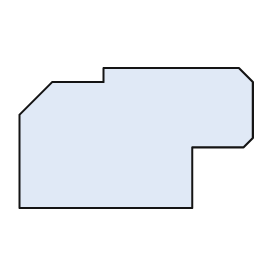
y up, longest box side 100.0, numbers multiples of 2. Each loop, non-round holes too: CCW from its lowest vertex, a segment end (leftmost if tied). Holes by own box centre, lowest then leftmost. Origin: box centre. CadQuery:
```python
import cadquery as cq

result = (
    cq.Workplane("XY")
    .moveTo(-50.0, -30.0)
    .lineTo(24.0, -30.0)
    .lineTo(24.0, -4.0)
    .lineTo(46.0, -4.0)
    .lineTo(50.0, 0.0)
    .lineTo(50.0, 24.0)
    .lineTo(44.0, 30.0)
    .lineTo(-14.0, 30.0)
    .lineTo(-14.0, 24.0)
    .lineTo(-36.0, 24.0)
    .lineTo(-50.0, 10.0)
    .close()
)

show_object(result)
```